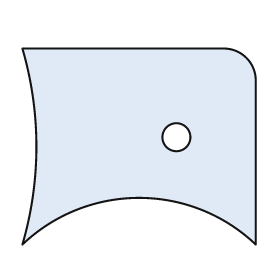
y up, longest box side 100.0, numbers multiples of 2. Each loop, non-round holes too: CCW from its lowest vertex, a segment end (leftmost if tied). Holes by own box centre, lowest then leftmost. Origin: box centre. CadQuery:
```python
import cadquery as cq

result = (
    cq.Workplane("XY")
    .moveTo(-50.0, -42.0)
    .threePointArc((0.0, -22.0), (50.0, -42.0))
    .lineTo(50.0, 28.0)
    .threePointArc((46.0, 38.0), (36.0, 42.0))
    .lineTo(-50.0, 42.0)
    .threePointArc((-44.0, 0.0), (-50.0, -42.0))
    .close()
    .moveTo(16.0, 4.0)
    .circle(6.0)
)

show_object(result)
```